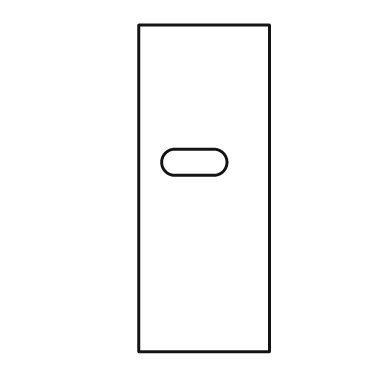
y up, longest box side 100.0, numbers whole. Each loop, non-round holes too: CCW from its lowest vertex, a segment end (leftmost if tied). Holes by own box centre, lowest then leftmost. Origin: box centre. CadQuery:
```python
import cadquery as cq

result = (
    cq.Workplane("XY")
    .moveTo(-20.0, -50.0)
    .lineTo(20.0, -50.0)
    .lineTo(20.0, 50.0)
    .lineTo(-20.0, 50.0)
    .close()
    .moveTo(-9.0, 4.0)
    .lineTo(3.0, 4.0)
    .threePointArc((7.0, 8.0), (3.0, 12.0))
    .lineTo(-9.0, 12.0)
    .threePointArc((-13.0, 8.0), (-9.0, 4.0))
    .close()
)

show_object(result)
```